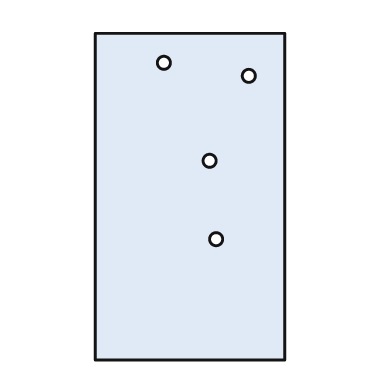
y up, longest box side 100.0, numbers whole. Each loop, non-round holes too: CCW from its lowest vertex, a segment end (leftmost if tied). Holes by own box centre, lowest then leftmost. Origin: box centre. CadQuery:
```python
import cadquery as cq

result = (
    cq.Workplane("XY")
    .moveTo(-29.0, -50.0)
    .lineTo(29.0, -50.0)
    .lineTo(29.0, 50.0)
    .lineTo(-29.0, 50.0)
    .close()
    .moveTo(8.0, -13.0)
    .circle(2.0)
    .moveTo(6.0, 11.0)
    .circle(2.0)
    .moveTo(18.0, 37.0)
    .circle(2.0)
    .moveTo(-8.0, 41.0)
    .circle(2.0)
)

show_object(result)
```